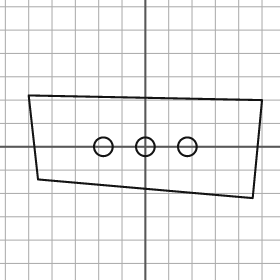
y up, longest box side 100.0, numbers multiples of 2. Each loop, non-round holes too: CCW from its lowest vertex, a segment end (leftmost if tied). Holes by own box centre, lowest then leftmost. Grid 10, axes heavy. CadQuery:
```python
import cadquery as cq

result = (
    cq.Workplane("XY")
    .moveTo(46.0, -22.0)
    .lineTo(50.0, 20.0)
    .lineTo(-50.0, 22.0)
    .lineTo(-46.0, -14.0)
    .close()
    .moveTo(-18.0, 0.0)
    .circle(4.0)
    .moveTo(0.0, 0.0)
    .circle(4.0)
    .moveTo(18.0, 0.0)
    .circle(4.0)
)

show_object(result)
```